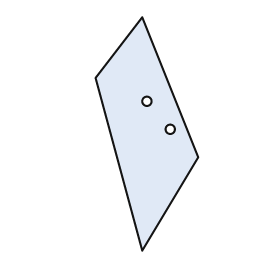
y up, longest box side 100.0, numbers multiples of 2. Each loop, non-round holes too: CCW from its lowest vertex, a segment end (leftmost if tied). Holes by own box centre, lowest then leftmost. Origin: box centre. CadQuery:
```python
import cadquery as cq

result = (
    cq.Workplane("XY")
    .moveTo(-2.0, -50.0)
    .lineTo(22.0, -10.0)
    .lineTo(-2.0, 50.0)
    .lineTo(-22.0, 24.0)
    .close()
    .moveTo(10.0, 2.0)
    .circle(2.0)
    .moveTo(0.0, 14.0)
    .circle(2.0)
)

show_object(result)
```